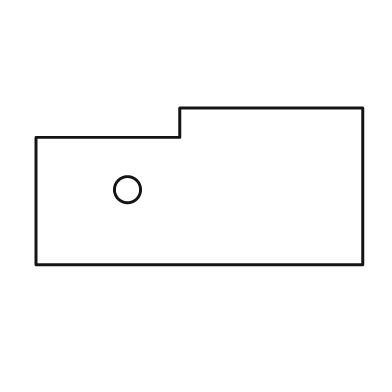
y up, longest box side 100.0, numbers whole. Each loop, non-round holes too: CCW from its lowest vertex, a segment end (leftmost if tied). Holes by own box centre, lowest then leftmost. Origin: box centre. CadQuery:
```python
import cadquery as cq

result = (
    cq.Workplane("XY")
    .moveTo(-50.0, -24.0)
    .lineTo(50.0, -24.0)
    .lineTo(50.0, 24.0)
    .lineTo(-6.0, 24.0)
    .lineTo(-6.0, 15.0)
    .lineTo(-50.0, 15.0)
    .close()
    .moveTo(-22.0, -1.0)
    .circle(4.0)
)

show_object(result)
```